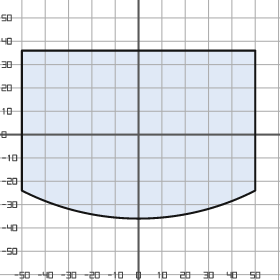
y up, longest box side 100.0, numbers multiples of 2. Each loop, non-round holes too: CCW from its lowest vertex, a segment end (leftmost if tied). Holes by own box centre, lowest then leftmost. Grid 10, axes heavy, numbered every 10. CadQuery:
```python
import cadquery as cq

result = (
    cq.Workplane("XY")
    .moveTo(-50.0, -24.0)
    .threePointArc((0.0, -36.0), (50.0, -24.0))
    .lineTo(50.0, 36.0)
    .lineTo(-50.0, 36.0)
    .close()
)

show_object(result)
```